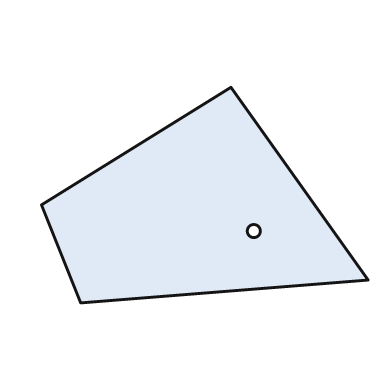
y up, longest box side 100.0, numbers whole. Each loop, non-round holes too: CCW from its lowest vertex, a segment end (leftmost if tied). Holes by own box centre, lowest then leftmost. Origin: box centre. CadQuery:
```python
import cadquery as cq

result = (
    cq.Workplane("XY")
    .moveTo(-38.0, -33.0)
    .lineTo(50.0, -26.0)
    .lineTo(8.0, 33.0)
    .lineTo(-50.0, -3.0)
    .close()
    .moveTo(15.0, -11.0)
    .circle(2.0)
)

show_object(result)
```